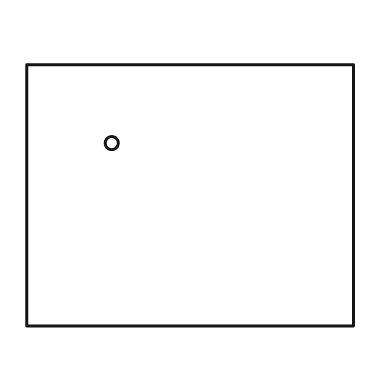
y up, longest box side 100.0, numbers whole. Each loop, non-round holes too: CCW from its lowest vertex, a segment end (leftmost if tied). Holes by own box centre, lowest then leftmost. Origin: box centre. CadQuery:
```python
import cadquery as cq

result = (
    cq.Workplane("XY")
    .moveTo(-50.0, -40.0)
    .lineTo(50.0, -40.0)
    .lineTo(50.0, 40.0)
    .lineTo(-50.0, 40.0)
    .close()
    .moveTo(-24.0, 16.0)
    .circle(2.0)
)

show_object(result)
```